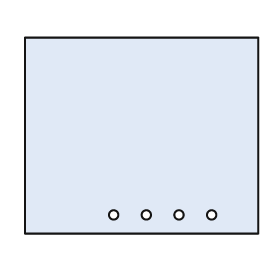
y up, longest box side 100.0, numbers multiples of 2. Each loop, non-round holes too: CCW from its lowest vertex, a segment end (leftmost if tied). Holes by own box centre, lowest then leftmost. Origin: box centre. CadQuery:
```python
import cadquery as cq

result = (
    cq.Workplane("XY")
    .moveTo(-50.0, -42.0)
    .lineTo(50.0, -42.0)
    .lineTo(50.0, 42.0)
    .lineTo(-50.0, 42.0)
    .close()
    .moveTo(-12.0, -34.0)
    .circle(2.0)
    .moveTo(2.0, -34.0)
    .circle(2.0)
    .moveTo(16.0, -34.0)
    .circle(2.0)
    .moveTo(30.0, -34.0)
    .circle(2.0)
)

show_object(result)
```